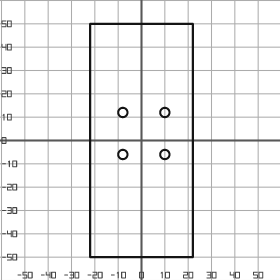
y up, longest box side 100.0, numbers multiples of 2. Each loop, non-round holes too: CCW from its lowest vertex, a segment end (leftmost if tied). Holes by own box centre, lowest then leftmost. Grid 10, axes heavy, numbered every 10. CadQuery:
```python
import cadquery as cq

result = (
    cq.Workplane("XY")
    .moveTo(-22.0, -50.0)
    .lineTo(22.0, -50.0)
    .lineTo(22.0, 50.0)
    .lineTo(-22.0, 50.0)
    .close()
    .moveTo(-8.0, -6.0)
    .circle(2.0)
    .moveTo(10.0, -6.0)
    .circle(2.0)
    .moveTo(-8.0, 12.0)
    .circle(2.0)
    .moveTo(10.0, 12.0)
    .circle(2.0)
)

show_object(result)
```